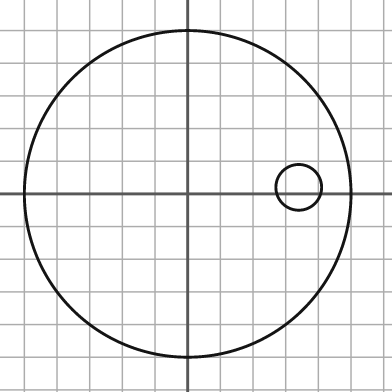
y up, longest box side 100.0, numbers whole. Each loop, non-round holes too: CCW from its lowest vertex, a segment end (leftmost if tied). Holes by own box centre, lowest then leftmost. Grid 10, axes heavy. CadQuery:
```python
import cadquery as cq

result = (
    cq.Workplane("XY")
    .moveTo(0.0, 0.0)
    .circle(50.0)
    .moveTo(34.0, 2.0)
    .circle(7.0)
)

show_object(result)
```